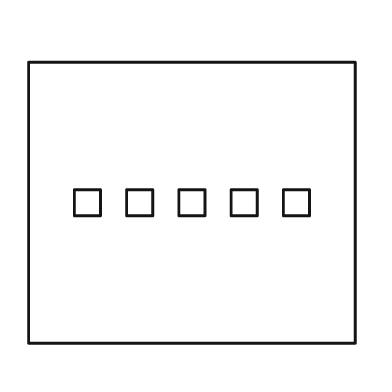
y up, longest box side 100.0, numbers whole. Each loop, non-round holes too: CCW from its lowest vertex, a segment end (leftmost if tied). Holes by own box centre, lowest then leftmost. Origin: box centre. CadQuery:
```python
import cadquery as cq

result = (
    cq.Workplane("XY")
    .moveTo(-50.0, -43.0)
    .lineTo(50.0, -43.0)
    .lineTo(50.0, 43.0)
    .lineTo(-50.0, 43.0)
    .close()
    .moveTo(-36.0, -4.0)
    .lineTo(-28.0, -4.0)
    .lineTo(-28.0, 4.0)
    .lineTo(-36.0, 4.0)
    .close()
    .moveTo(-20.0, -4.0)
    .lineTo(-12.0, -4.0)
    .lineTo(-12.0, 4.0)
    .lineTo(-20.0, 4.0)
    .close()
    .moveTo(-4.0, -4.0)
    .lineTo(4.0, -4.0)
    .lineTo(4.0, 4.0)
    .lineTo(-4.0, 4.0)
    .close()
    .moveTo(12.0, -4.0)
    .lineTo(20.0, -4.0)
    .lineTo(20.0, 4.0)
    .lineTo(12.0, 4.0)
    .close()
    .moveTo(28.0, -4.0)
    .lineTo(36.0, -4.0)
    .lineTo(36.0, 4.0)
    .lineTo(28.0, 4.0)
    .close()
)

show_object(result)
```